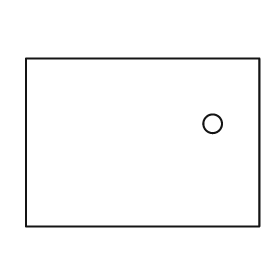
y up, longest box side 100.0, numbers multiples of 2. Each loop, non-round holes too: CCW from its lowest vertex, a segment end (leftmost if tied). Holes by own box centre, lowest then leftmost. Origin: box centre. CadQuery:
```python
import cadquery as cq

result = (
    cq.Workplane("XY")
    .moveTo(-50.0, -36.0)
    .lineTo(50.0, -36.0)
    .lineTo(50.0, 36.0)
    .lineTo(-50.0, 36.0)
    .close()
    .moveTo(30.0, 8.0)
    .circle(4.0)
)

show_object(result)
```